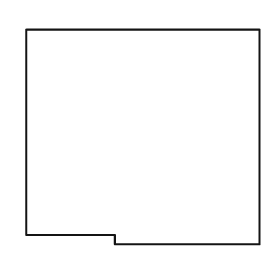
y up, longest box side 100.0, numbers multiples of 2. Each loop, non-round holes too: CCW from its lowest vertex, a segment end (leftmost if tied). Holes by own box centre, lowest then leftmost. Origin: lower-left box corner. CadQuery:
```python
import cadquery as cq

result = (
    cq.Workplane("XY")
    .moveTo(38.0, 0.0)
    .lineTo(100.0, 0.0)
    .lineTo(100.0, 92.0)
    .lineTo(0.0, 92.0)
    .lineTo(0.0, 4.0)
    .lineTo(38.0, 4.0)
    .close()
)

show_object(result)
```